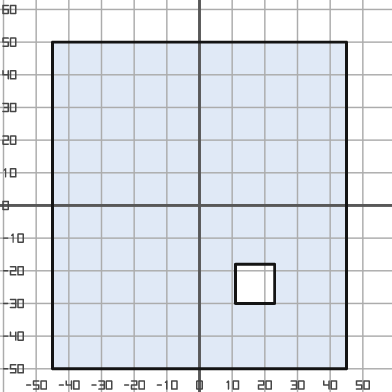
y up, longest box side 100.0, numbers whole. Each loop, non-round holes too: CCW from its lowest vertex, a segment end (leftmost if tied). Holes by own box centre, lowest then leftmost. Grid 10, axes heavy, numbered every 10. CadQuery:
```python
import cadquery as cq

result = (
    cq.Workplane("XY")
    .moveTo(-45.0, -50.0)
    .lineTo(45.0, -50.0)
    .lineTo(45.0, 50.0)
    .lineTo(-45.0, 50.0)
    .close()
    .moveTo(11.0, -30.0)
    .lineTo(23.0, -30.0)
    .lineTo(23.0, -18.0)
    .lineTo(11.0, -18.0)
    .close()
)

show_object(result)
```